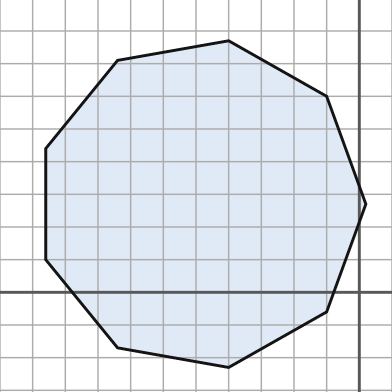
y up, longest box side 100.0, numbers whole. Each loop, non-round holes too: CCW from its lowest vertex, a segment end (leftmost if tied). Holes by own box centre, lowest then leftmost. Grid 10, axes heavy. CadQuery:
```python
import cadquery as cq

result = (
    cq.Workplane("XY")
    .moveTo(-40.0, -23.0)
    .lineTo(-10.0, -6.0)
    .lineTo(2.0, 27.0)
    .lineTo(-10.0, 60.0)
    .lineTo(-40.0, 77.0)
    .lineTo(-74.0, 71.0)
    .lineTo(-96.0, 44.0)
    .lineTo(-96.0, 10.0)
    .lineTo(-74.0, -17.0)
    .close()
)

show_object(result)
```